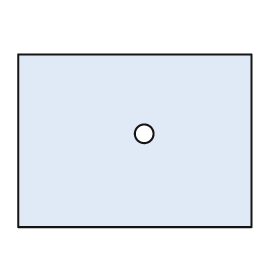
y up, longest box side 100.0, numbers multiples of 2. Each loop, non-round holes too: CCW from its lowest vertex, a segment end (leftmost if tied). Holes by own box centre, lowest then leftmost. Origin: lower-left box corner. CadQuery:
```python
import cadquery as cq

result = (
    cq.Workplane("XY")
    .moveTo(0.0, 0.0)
    .lineTo(100.0, 0.0)
    .lineTo(100.0, 74.0)
    .lineTo(0.0, 74.0)
    .close()
    .moveTo(54.0, 40.0)
    .circle(4.0)
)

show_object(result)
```